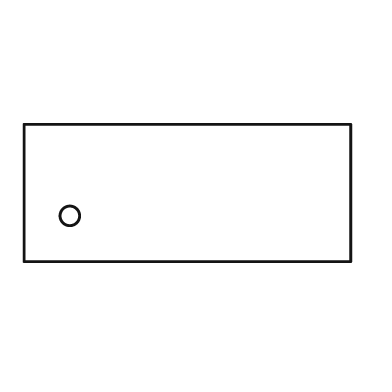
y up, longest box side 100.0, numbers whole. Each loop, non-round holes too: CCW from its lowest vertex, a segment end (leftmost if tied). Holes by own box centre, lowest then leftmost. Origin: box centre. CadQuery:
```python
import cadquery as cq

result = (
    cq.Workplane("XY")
    .moveTo(-50.0, -21.0)
    .lineTo(50.0, -21.0)
    .lineTo(50.0, 21.0)
    .lineTo(-50.0, 21.0)
    .close()
    .moveTo(-36.0, -7.0)
    .circle(3.0)
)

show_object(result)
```